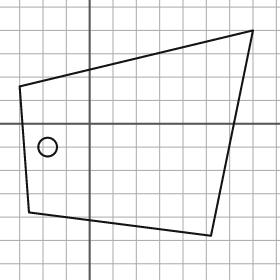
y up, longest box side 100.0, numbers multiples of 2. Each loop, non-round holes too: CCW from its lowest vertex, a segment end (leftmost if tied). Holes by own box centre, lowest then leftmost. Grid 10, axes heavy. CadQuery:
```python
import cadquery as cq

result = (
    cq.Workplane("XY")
    .moveTo(52.0, -48.0)
    .lineTo(70.0, 40.0)
    .lineTo(-30.0, 16.0)
    .lineTo(-26.0, -38.0)
    .close()
    .moveTo(-18.0, -10.0)
    .circle(4.0)
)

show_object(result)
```